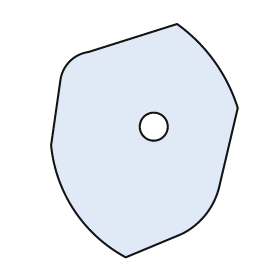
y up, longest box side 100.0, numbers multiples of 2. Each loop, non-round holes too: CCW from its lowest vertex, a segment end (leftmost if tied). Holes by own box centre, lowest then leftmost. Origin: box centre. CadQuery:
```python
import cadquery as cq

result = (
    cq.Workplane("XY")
    .moveTo(-8.0, -50.0)
    .lineTo(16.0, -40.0)
    .threePointArc((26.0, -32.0), (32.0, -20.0))
    .lineTo(40.0, 14.0)
    .threePointArc((30.0, 34.0), (14.0, 50.0))
    .lineTo(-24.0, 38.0)
    .threePointArc((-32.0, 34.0), (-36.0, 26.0))
    .lineTo(-40.0, -2.0)
    .threePointArc((-30.0, -30.0), (-8.0, -50.0))
    .close()
    .moveTo(4.0, 6.0)
    .circle(6.0)
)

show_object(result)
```